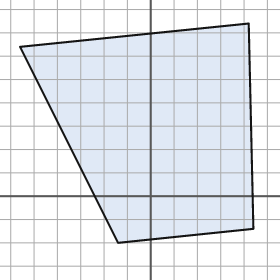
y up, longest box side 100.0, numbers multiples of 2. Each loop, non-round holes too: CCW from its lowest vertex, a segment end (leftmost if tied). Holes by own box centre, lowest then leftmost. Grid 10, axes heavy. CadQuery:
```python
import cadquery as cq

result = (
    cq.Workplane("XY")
    .moveTo(-14.0, -20.0)
    .lineTo(44.0, -14.0)
    .lineTo(42.0, 74.0)
    .lineTo(-56.0, 64.0)
    .close()
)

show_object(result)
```